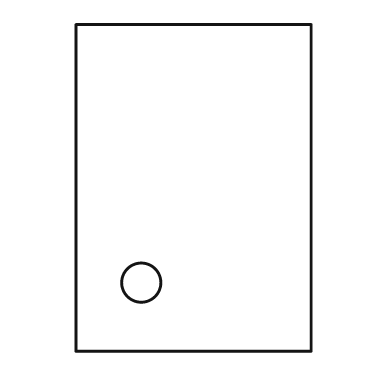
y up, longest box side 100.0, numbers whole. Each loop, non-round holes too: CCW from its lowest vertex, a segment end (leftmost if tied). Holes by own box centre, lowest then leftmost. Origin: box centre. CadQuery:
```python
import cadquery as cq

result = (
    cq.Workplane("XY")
    .moveTo(-36.0, -50.0)
    .lineTo(36.0, -50.0)
    .lineTo(36.0, 50.0)
    .lineTo(-36.0, 50.0)
    .close()
    .moveTo(-16.0, -29.0)
    .circle(6.0)
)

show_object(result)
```